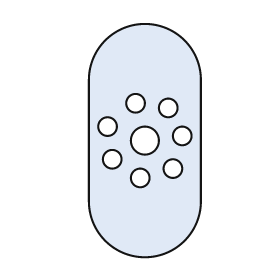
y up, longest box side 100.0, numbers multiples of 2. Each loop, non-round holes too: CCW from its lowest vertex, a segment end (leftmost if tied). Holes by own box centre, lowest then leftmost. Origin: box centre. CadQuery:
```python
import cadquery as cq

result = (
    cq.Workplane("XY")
    .moveTo(-24.0, -26.0)
    .threePointArc((0.0, -50.0), (24.0, -26.0))
    .lineTo(24.0, 26.0)
    .threePointArc((0.0, 50.0), (-24.0, 26.0))
    .close()
    .moveTo(-2.0, -16.0)
    .circle(4.0)
    .moveTo(12.0, -12.0)
    .circle(4.0)
    .moveTo(-14.0, -8.0)
    .circle(4.0)
    .moveTo(0.0, 0.0)
    .circle(6.0)
    .moveTo(16.0, 2.0)
    .circle(4.0)
    .moveTo(-16.0, 6.0)
    .circle(4.0)
    .moveTo(10.0, 14.0)
    .circle(4.0)
    .moveTo(-4.0, 16.0)
    .circle(4.0)
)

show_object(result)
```